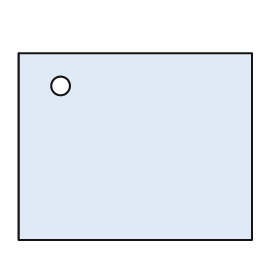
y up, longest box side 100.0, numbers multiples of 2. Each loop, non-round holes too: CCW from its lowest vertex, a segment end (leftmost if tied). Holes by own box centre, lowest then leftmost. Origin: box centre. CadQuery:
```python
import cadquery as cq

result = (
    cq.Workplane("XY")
    .moveTo(-50.0, -40.0)
    .lineTo(50.0, -40.0)
    .lineTo(50.0, 40.0)
    .lineTo(-50.0, 40.0)
    .close()
    .moveTo(-32.0, 26.0)
    .circle(4.0)
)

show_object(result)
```